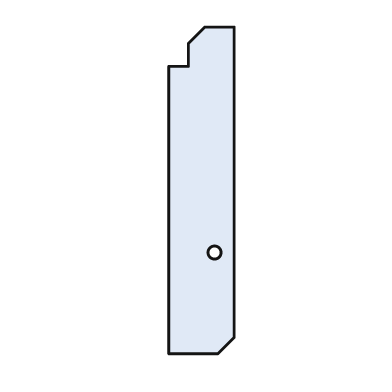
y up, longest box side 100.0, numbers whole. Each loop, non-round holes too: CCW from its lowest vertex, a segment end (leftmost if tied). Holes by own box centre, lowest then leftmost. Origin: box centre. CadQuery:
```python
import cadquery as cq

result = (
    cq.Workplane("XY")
    .moveTo(-10.0, -50.0)
    .lineTo(5.0, -50.0)
    .lineTo(10.0, -45.0)
    .lineTo(10.0, 50.0)
    .lineTo(1.0, 50.0)
    .lineTo(-4.0, 45.0)
    .lineTo(-4.0, 38.0)
    .lineTo(-10.0, 38.0)
    .close()
    .moveTo(4.0, -19.0)
    .circle(2.0)
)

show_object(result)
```